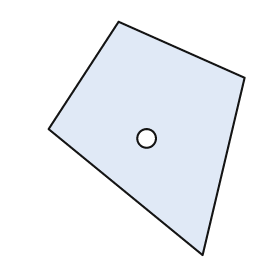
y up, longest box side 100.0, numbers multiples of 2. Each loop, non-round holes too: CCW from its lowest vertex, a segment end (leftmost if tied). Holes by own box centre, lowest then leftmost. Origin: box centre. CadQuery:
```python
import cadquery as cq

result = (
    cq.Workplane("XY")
    .moveTo(24.0, -50.0)
    .lineTo(42.0, 26.0)
    .lineTo(-12.0, 50.0)
    .lineTo(-42.0, 4.0)
    .close()
    .moveTo(0.0, 0.0)
    .circle(4.0)
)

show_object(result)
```